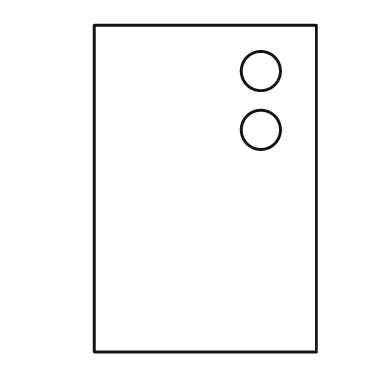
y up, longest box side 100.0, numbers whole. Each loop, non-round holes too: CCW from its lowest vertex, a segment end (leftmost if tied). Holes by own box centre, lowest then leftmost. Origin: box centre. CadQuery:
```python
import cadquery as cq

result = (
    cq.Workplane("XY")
    .moveTo(-34.0, -50.0)
    .lineTo(34.0, -50.0)
    .lineTo(34.0, 50.0)
    .lineTo(-34.0, 50.0)
    .close()
    .moveTo(17.0, 18.0)
    .circle(6.0)
    .moveTo(17.0, 36.0)
    .circle(6.0)
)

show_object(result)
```